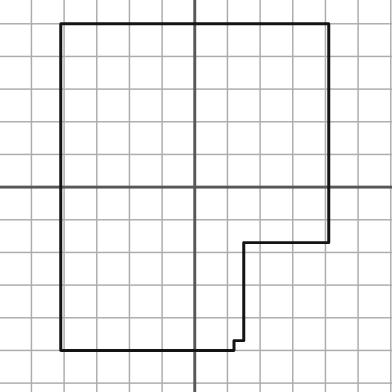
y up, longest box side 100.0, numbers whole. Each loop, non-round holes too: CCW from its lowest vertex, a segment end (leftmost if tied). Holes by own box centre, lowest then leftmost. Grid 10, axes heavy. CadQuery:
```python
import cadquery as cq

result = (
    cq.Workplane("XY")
    .moveTo(-41.0, -50.0)
    .lineTo(12.0, -50.0)
    .lineTo(12.0, -47.0)
    .lineTo(15.0, -47.0)
    .lineTo(15.0, -17.0)
    .lineTo(41.0, -17.0)
    .lineTo(41.0, 50.0)
    .lineTo(-41.0, 50.0)
    .close()
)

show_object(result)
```